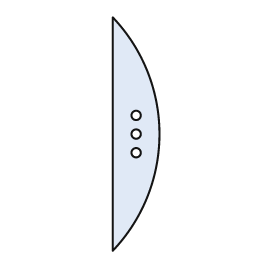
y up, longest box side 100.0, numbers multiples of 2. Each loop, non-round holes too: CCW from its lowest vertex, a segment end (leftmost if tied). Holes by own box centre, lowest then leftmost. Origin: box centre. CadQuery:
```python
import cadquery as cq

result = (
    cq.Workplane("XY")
    .moveTo(-10.0, -50.0)
    .threePointArc((10.0, 0.0), (-10.0, 50.0))
    .close()
    .moveTo(0.0, -8.0)
    .circle(2.0)
    .moveTo(0.0, 0.0)
    .circle(2.0)
    .moveTo(0.0, 8.0)
    .circle(2.0)
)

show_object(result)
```